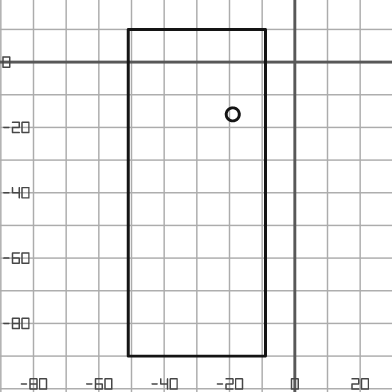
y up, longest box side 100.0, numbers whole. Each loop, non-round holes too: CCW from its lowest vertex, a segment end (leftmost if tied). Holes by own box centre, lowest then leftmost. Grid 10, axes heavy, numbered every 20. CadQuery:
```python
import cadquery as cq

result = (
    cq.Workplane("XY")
    .moveTo(-51.0, -90.0)
    .lineTo(-9.0, -90.0)
    .lineTo(-9.0, 10.0)
    .lineTo(-51.0, 10.0)
    .close()
    .moveTo(-19.0, -16.0)
    .circle(2.0)
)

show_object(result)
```